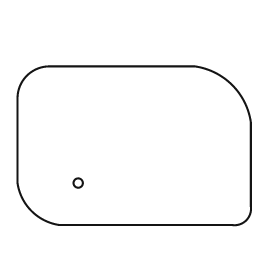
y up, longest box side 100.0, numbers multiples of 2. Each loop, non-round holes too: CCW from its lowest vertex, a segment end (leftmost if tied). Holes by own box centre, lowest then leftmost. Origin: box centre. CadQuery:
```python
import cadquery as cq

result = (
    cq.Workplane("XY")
    .moveTo(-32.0, -34.0)
    .lineTo(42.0, -34.0)
    .threePointArc((48.0, -32.0), (50.0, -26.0))
    .lineTo(50.0, 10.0)
    .threePointArc((42.0, 26.0), (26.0, 34.0))
    .lineTo(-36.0, 34.0)
    .threePointArc((-46.0, 30.0), (-50.0, 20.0))
    .lineTo(-50.0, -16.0)
    .threePointArc((-44.0, -28.0), (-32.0, -34.0))
    .close()
    .moveTo(-24.0, -16.0)
    .circle(2.0)
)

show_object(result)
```